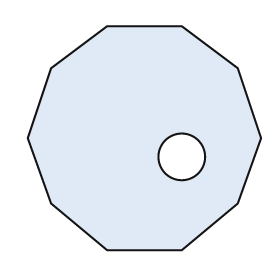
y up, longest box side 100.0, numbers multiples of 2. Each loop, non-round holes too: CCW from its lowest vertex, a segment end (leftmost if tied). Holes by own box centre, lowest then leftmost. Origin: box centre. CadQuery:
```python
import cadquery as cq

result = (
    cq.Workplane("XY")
    .moveTo(-16.0, -48.0)
    .lineTo(16.0, -48.0)
    .lineTo(40.0, -28.0)
    .lineTo(50.0, 0.0)
    .lineTo(40.0, 30.0)
    .lineTo(16.0, 48.0)
    .lineTo(-16.0, 48.0)
    .lineTo(-40.0, 30.0)
    .lineTo(-50.0, 0.0)
    .lineTo(-40.0, -28.0)
    .close()
    .moveTo(16.0, -8.0)
    .circle(10.0)
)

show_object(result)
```